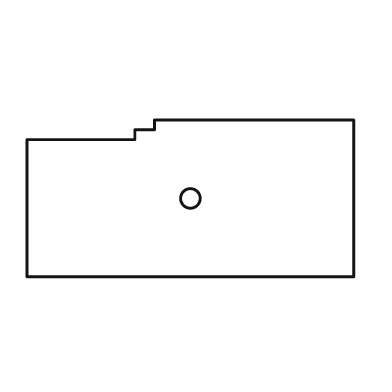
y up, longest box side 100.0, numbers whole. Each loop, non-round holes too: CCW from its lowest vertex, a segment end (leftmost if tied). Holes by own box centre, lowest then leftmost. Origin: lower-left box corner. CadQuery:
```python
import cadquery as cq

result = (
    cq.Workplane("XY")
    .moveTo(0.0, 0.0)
    .lineTo(100.0, 0.0)
    .lineTo(100.0, 48.0)
    .lineTo(39.0, 48.0)
    .lineTo(39.0, 45.0)
    .lineTo(33.0, 45.0)
    .lineTo(33.0, 42.0)
    .lineTo(0.0, 42.0)
    .close()
    .moveTo(50.0, 24.0)
    .circle(3.0)
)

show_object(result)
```